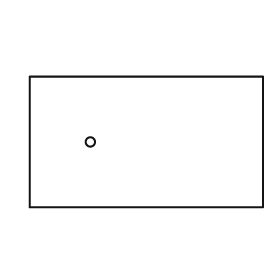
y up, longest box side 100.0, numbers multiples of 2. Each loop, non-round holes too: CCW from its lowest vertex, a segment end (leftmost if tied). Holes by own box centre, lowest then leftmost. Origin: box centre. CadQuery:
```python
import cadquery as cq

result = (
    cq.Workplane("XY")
    .moveTo(-50.0, -28.0)
    .lineTo(50.0, -28.0)
    .lineTo(50.0, 28.0)
    .lineTo(-50.0, 28.0)
    .close()
    .moveTo(-24.0, 0.0)
    .circle(2.0)
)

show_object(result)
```